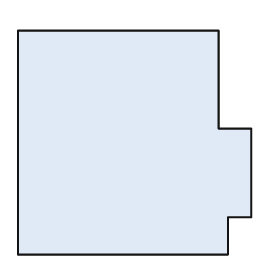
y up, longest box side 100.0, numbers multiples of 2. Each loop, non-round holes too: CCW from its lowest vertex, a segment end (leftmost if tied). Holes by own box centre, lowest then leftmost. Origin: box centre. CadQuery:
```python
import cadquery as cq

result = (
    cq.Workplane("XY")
    .moveTo(-50.0, -48.0)
    .lineTo(40.0, -48.0)
    .lineTo(40.0, -32.0)
    .lineTo(50.0, -32.0)
    .lineTo(50.0, 6.0)
    .lineTo(36.0, 6.0)
    .lineTo(36.0, 48.0)
    .lineTo(-50.0, 48.0)
    .close()
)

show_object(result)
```